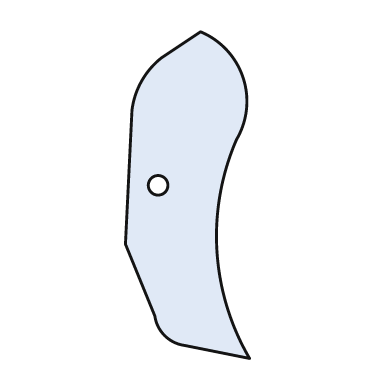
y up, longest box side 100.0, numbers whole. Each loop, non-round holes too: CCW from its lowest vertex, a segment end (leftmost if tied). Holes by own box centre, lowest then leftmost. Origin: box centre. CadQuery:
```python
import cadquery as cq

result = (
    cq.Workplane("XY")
    .moveTo(19.0, -50.0)
    .threePointArc((9.0, -17.0), (15.0, 17.0))
    .threePointArc((17.0, 36.0), (4.0, 50.0))
    .lineTo(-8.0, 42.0)
    .threePointArc((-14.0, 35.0), (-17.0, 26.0))
    .lineTo(-19.0, -15.0)
    .lineTo(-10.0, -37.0)
    .threePointArc((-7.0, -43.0), (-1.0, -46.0))
    .close()
    .moveTo(-9.0, 3.0)
    .circle(3.0)
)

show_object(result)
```